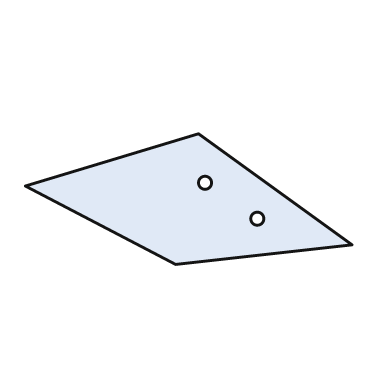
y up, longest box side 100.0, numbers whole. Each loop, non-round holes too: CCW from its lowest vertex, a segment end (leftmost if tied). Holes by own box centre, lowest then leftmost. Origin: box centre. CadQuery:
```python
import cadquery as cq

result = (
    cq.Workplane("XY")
    .moveTo(-4.0, -20.0)
    .lineTo(50.0, -14.0)
    .lineTo(3.0, 20.0)
    .lineTo(-50.0, 4.0)
    .close()
    .moveTo(21.0, -6.0)
    .circle(2.0)
    .moveTo(5.0, 5.0)
    .circle(2.0)
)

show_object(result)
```